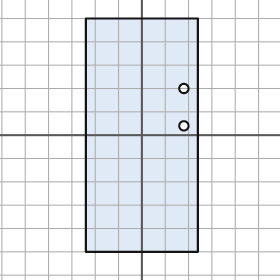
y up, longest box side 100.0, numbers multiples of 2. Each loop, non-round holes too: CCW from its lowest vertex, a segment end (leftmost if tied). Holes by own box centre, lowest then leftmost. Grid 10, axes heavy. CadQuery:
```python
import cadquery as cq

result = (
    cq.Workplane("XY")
    .moveTo(-24.0, -50.0)
    .lineTo(24.0, -50.0)
    .lineTo(24.0, 50.0)
    .lineTo(-24.0, 50.0)
    .close()
    .moveTo(18.0, 4.0)
    .circle(2.0)
    .moveTo(18.0, 20.0)
    .circle(2.0)
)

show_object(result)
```